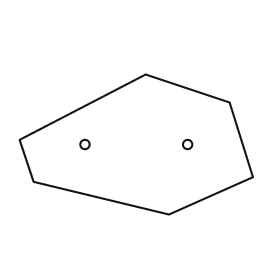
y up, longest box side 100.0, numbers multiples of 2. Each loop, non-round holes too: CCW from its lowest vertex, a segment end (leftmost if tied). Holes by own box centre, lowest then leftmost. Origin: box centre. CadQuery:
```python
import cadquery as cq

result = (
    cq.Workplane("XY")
    .moveTo(14.0, -30.0)
    .lineTo(50.0, -14.0)
    .lineTo(40.0, 18.0)
    .lineTo(4.0, 30.0)
    .lineTo(-50.0, 2.0)
    .lineTo(-44.0, -16.0)
    .close()
    .moveTo(-22.0, 0.0)
    .circle(2.0)
    .moveTo(22.0, 0.0)
    .circle(2.0)
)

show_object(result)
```